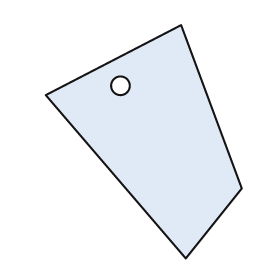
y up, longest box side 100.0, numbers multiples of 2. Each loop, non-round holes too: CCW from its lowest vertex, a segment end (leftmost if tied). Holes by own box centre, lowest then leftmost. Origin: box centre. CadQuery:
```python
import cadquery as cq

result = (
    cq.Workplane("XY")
    .moveTo(18.0, -50.0)
    .lineTo(42.0, -20.0)
    .lineTo(16.0, 50.0)
    .lineTo(-42.0, 20.0)
    .close()
    .moveTo(-10.0, 24.0)
    .circle(4.0)
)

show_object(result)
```